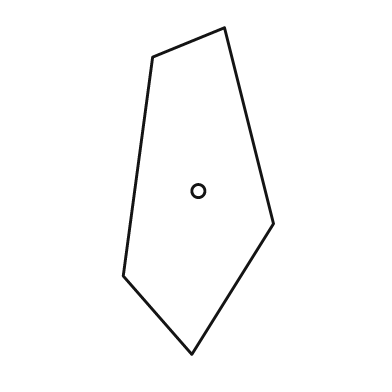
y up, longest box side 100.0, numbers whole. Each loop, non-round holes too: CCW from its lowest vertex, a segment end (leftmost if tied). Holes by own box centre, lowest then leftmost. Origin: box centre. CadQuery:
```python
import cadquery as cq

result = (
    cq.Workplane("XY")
    .moveTo(-2.0, -50.0)
    .lineTo(23.0, -10.0)
    .lineTo(8.0, 50.0)
    .lineTo(-14.0, 41.0)
    .lineTo(-23.0, -26.0)
    .close()
    .moveTo(0.0, 0.0)
    .circle(2.0)
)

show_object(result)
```